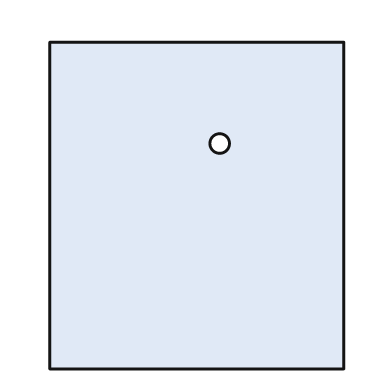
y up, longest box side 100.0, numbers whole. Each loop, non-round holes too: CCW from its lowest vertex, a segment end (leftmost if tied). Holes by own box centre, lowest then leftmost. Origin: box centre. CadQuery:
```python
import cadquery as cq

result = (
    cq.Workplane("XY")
    .moveTo(-45.0, -50.0)
    .lineTo(45.0, -50.0)
    .lineTo(45.0, 50.0)
    .lineTo(-45.0, 50.0)
    .close()
    .moveTo(7.0, 19.0)
    .circle(3.0)
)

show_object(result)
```